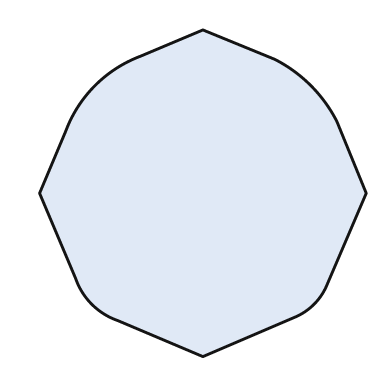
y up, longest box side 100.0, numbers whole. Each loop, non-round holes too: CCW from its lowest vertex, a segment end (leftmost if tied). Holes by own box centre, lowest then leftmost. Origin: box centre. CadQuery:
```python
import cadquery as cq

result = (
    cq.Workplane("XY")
    .moveTo(0.0, -50.0)
    .lineTo(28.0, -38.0)
    .threePointArc((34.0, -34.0), (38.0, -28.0))
    .lineTo(50.0, 0.0)
    .lineTo(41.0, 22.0)
    .threePointArc((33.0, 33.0), (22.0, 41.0))
    .lineTo(0.0, 50.0)
    .lineTo(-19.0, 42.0)
    .threePointArc((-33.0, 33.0), (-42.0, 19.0))
    .lineTo(-50.0, 0.0)
    .lineTo(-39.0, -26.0)
    .threePointArc((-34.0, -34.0), (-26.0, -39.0))
    .close()
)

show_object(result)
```